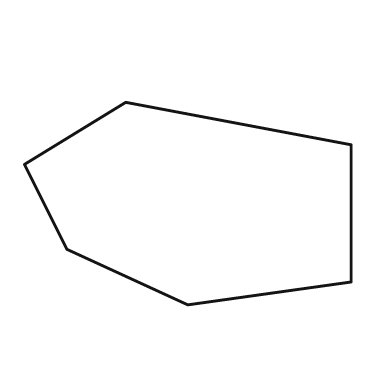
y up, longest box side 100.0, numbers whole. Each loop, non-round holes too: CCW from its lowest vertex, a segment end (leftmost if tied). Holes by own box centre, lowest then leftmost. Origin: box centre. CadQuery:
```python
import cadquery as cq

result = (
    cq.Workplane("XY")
    .moveTo(0.0, -31.0)
    .lineTo(50.0, -24.0)
    .lineTo(50.0, 18.0)
    .lineTo(-19.0, 31.0)
    .lineTo(-50.0, 12.0)
    .lineTo(-37.0, -14.0)
    .close()
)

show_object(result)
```